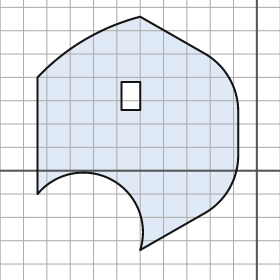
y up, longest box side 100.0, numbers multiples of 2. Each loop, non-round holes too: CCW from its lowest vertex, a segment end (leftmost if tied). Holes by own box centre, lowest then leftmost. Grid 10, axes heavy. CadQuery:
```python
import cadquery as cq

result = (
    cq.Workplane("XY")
    .moveTo(-50.0, -34.0)
    .lineTo(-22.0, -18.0)
    .threePointArc((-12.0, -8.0), (-8.0, 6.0))
    .lineTo(-8.0, 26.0)
    .threePointArc((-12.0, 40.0), (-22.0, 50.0))
    .lineTo(-50.0, 66.0)
    .threePointArc((-74.0, 56.0), (-94.0, 40.0))
    .lineTo(-94.0, -10.0)
    .threePointArc((-62.0, -4.0), (-50.0, -34.0))
    .close()
    .moveTo(-58.0, 26.0)
    .lineTo(-50.0, 26.0)
    .lineTo(-50.0, 38.0)
    .lineTo(-58.0, 38.0)
    .close()
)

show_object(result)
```